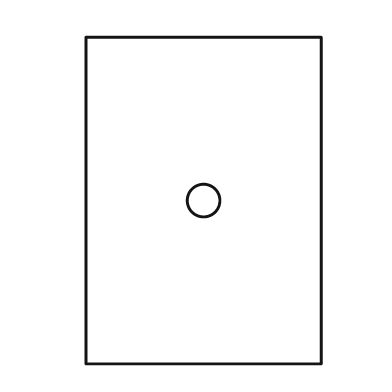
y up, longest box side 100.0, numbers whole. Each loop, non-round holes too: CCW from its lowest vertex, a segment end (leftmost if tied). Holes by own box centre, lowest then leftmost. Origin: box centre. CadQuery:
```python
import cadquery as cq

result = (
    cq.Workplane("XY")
    .moveTo(-36.0, -50.0)
    .lineTo(36.0, -50.0)
    .lineTo(36.0, 50.0)
    .lineTo(-36.0, 50.0)
    .close()
    .moveTo(0.0, 0.0)
    .circle(5.0)
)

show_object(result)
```